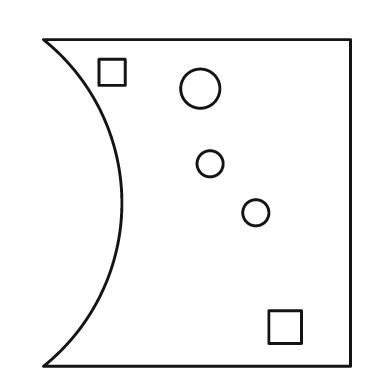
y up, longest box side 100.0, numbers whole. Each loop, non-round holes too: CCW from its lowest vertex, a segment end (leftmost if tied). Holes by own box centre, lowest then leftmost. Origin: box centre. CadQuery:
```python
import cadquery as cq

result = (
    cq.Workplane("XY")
    .moveTo(-47.0, -50.0)
    .lineTo(47.0, -50.0)
    .lineTo(47.0, 50.0)
    .lineTo(-47.0, 50.0)
    .threePointArc((-23.0, 0.0), (-47.0, -50.0))
    .close()
    .moveTo(22.0, -43.0)
    .lineTo(32.0, -43.0)
    .lineTo(32.0, -33.0)
    .lineTo(22.0, -33.0)
    .close()
    .moveTo(18.0, -3.0)
    .circle(4.0)
    .moveTo(4.0, 12.0)
    .circle(4.0)
    .moveTo(1.0, 35.0)
    .circle(6.0)
    .moveTo(-30.0, 36.0)
    .lineTo(-22.0, 36.0)
    .lineTo(-22.0, 44.0)
    .lineTo(-30.0, 44.0)
    .close()
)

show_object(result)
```